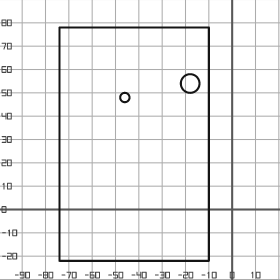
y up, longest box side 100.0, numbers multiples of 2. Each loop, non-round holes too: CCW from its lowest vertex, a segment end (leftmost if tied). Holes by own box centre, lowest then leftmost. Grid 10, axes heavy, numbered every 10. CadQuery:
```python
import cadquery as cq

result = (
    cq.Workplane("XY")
    .moveTo(-74.0, -22.0)
    .lineTo(-10.0, -22.0)
    .lineTo(-10.0, 78.0)
    .lineTo(-74.0, 78.0)
    .close()
    .moveTo(-46.0, 48.0)
    .circle(2.0)
    .moveTo(-18.0, 54.0)
    .circle(4.0)
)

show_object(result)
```